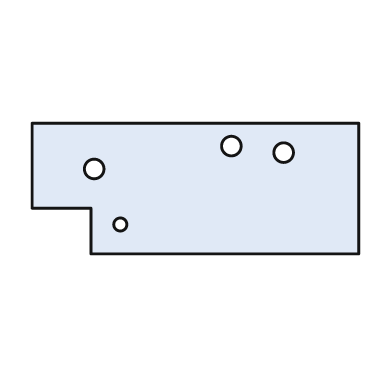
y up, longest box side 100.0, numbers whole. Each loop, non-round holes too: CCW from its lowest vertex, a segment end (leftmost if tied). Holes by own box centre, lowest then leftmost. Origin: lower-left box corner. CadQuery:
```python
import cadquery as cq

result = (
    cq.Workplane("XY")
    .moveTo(18.0, 0.0)
    .lineTo(100.0, 0.0)
    .lineTo(100.0, 40.0)
    .lineTo(0.0, 40.0)
    .lineTo(0.0, 14.0)
    .lineTo(18.0, 14.0)
    .close()
    .moveTo(27.0, 9.0)
    .circle(2.0)
    .moveTo(19.0, 26.0)
    .circle(3.0)
    .moveTo(77.0, 31.0)
    .circle(3.0)
    .moveTo(61.0, 33.0)
    .circle(3.0)
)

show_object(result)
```